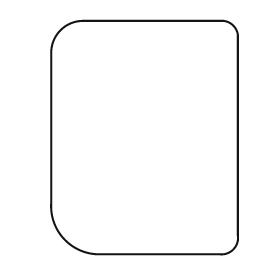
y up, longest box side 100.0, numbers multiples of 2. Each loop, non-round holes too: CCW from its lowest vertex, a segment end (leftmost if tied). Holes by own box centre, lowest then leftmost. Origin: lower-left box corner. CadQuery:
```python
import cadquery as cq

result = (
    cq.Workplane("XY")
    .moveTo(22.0, 0.0)
    .lineTo(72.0, 0.0)
    .threePointArc((78.0, 2.0), (80.0, 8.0))
    .lineTo(80.0, 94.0)
    .threePointArc((78.0, 98.0), (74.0, 100.0))
    .lineTo(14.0, 100.0)
    .threePointArc((4.0, 96.0), (0.0, 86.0))
    .lineTo(0.0, 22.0)
    .threePointArc((6.0, 6.0), (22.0, 0.0))
    .close()
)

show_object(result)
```